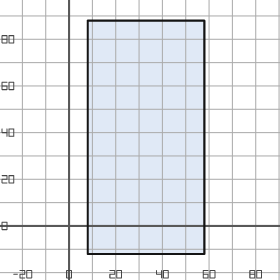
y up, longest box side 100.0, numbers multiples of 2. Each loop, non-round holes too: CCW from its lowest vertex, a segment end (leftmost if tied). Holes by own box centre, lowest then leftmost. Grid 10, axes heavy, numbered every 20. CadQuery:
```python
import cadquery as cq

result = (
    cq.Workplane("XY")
    .moveTo(8.0, -12.0)
    .lineTo(58.0, -12.0)
    .lineTo(58.0, 88.0)
    .lineTo(8.0, 88.0)
    .close()
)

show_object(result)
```